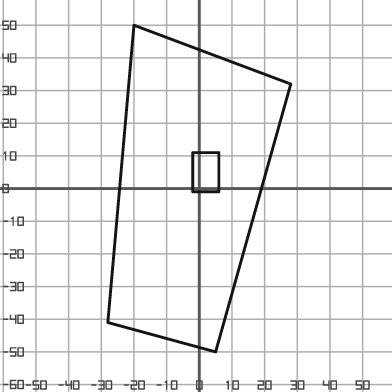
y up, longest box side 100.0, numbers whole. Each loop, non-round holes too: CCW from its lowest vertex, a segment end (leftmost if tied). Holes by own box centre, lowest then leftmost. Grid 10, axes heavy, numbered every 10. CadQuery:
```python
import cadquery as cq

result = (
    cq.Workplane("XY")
    .moveTo(5.0, -50.0)
    .lineTo(28.0, 32.0)
    .lineTo(-20.0, 50.0)
    .lineTo(-28.0, -41.0)
    .close()
    .moveTo(-2.0, -1.0)
    .lineTo(6.0, -1.0)
    .lineTo(6.0, 11.0)
    .lineTo(-2.0, 11.0)
    .close()
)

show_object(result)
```